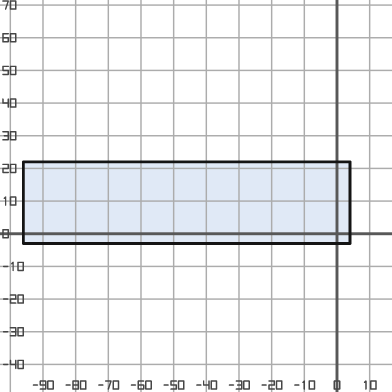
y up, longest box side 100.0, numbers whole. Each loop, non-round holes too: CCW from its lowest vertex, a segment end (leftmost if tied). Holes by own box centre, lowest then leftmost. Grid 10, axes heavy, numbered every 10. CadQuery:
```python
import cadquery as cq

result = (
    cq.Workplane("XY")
    .moveTo(-96.0, -3.0)
    .lineTo(4.0, -3.0)
    .lineTo(4.0, 22.0)
    .lineTo(-96.0, 22.0)
    .close()
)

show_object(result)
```